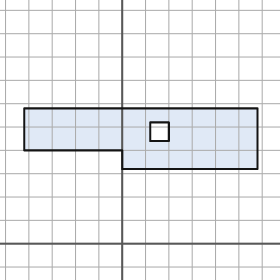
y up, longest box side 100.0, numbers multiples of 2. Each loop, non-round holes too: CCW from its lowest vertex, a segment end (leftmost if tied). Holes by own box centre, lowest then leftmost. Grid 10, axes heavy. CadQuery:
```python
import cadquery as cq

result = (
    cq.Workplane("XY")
    .moveTo(0.0, 32.0)
    .lineTo(58.0, 32.0)
    .lineTo(58.0, 58.0)
    .lineTo(-42.0, 58.0)
    .lineTo(-42.0, 40.0)
    .lineTo(0.0, 40.0)
    .close()
    .moveTo(12.0, 44.0)
    .lineTo(20.0, 44.0)
    .lineTo(20.0, 52.0)
    .lineTo(12.0, 52.0)
    .close()
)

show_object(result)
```